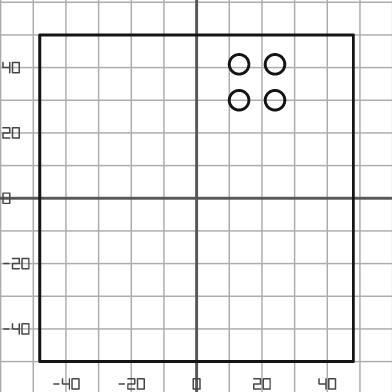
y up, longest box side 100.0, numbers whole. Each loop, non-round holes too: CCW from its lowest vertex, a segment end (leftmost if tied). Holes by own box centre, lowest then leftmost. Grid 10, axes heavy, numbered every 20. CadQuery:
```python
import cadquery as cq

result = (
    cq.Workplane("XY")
    .moveTo(-48.0, -50.0)
    .lineTo(48.0, -50.0)
    .lineTo(48.0, 50.0)
    .lineTo(-48.0, 50.0)
    .close()
    .moveTo(13.0, 30.0)
    .circle(3.0)
    .moveTo(24.0, 30.0)
    .circle(3.0)
    .moveTo(13.0, 41.0)
    .circle(3.0)
    .moveTo(24.0, 41.0)
    .circle(3.0)
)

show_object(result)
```